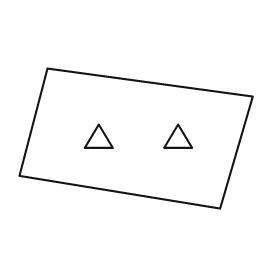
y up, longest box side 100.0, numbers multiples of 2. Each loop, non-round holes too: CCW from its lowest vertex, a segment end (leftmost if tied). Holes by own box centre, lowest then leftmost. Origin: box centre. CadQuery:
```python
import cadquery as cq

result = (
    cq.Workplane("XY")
    .moveTo(36.0, -30.0)
    .lineTo(50.0, 18.0)
    .lineTo(-38.0, 30.0)
    .lineTo(-50.0, -16.0)
    .close()
    .moveTo(-22.0, -4.0)
    .lineTo(-10.0, -4.0)
    .lineTo(-16.0, 6.0)
    .close()
    .moveTo(12.0, -4.0)
    .lineTo(24.0, -4.0)
    .lineTo(18.0, 6.0)
    .close()
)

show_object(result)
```